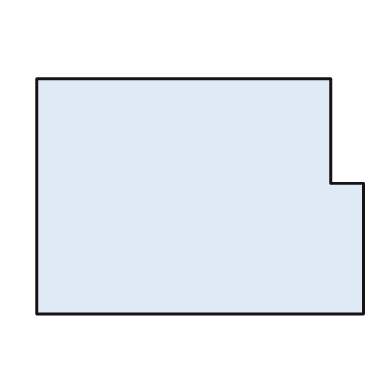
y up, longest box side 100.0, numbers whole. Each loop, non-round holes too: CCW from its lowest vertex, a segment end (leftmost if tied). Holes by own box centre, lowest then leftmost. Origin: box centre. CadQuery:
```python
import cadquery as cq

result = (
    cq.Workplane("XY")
    .moveTo(-50.0, -36.0)
    .lineTo(50.0, -36.0)
    .lineTo(50.0, 4.0)
    .lineTo(40.0, 4.0)
    .lineTo(40.0, 36.0)
    .lineTo(-50.0, 36.0)
    .close()
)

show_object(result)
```